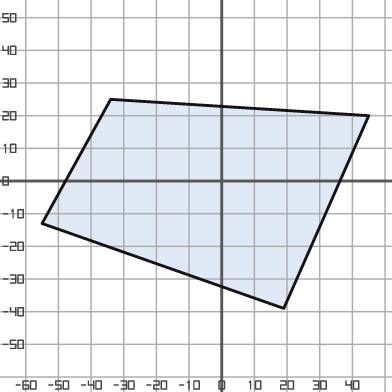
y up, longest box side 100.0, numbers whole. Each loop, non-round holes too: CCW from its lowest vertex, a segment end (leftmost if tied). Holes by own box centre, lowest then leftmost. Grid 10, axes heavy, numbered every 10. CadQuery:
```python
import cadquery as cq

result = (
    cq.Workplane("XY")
    .moveTo(19.0, -39.0)
    .lineTo(45.0, 20.0)
    .lineTo(-34.0, 25.0)
    .lineTo(-55.0, -13.0)
    .close()
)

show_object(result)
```